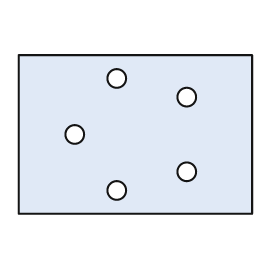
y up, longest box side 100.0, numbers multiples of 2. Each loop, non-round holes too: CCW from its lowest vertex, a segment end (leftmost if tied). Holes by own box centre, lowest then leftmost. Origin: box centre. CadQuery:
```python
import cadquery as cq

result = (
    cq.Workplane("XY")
    .moveTo(-50.0, -34.0)
    .lineTo(50.0, -34.0)
    .lineTo(50.0, 34.0)
    .lineTo(-50.0, 34.0)
    .close()
    .moveTo(-8.0, -24.0)
    .circle(4.0)
    .moveTo(22.0, -16.0)
    .circle(4.0)
    .moveTo(-26.0, 0.0)
    .circle(4.0)
    .moveTo(22.0, 16.0)
    .circle(4.0)
    .moveTo(-8.0, 24.0)
    .circle(4.0)
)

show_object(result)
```